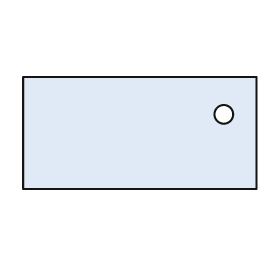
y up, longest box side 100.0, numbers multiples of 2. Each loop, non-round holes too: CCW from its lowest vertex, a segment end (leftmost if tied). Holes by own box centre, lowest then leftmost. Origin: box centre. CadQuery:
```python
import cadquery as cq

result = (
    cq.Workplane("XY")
    .moveTo(-50.0, -24.0)
    .lineTo(50.0, -24.0)
    .lineTo(50.0, 24.0)
    .lineTo(-50.0, 24.0)
    .close()
    .moveTo(36.0, 8.0)
    .circle(4.0)
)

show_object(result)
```